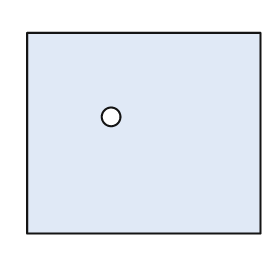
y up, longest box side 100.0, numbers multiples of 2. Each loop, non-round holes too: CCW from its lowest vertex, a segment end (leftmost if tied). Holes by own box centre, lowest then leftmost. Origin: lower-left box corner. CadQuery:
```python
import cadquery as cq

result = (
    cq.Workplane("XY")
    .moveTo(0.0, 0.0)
    .lineTo(100.0, 0.0)
    .lineTo(100.0, 86.0)
    .lineTo(0.0, 86.0)
    .close()
    .moveTo(36.0, 50.0)
    .circle(4.0)
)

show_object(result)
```